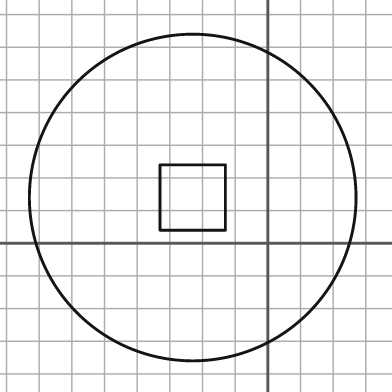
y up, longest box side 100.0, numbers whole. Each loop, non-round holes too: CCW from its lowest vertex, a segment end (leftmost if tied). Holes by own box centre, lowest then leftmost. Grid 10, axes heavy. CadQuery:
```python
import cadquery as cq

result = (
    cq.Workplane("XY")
    .moveTo(-23.0, 14.0)
    .circle(50.0)
    .moveTo(-33.0, 4.0)
    .lineTo(-13.0, 4.0)
    .lineTo(-13.0, 24.0)
    .lineTo(-33.0, 24.0)
    .close()
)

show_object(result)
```